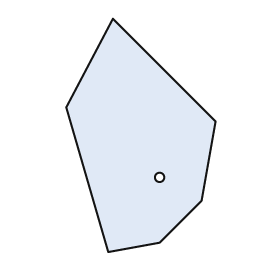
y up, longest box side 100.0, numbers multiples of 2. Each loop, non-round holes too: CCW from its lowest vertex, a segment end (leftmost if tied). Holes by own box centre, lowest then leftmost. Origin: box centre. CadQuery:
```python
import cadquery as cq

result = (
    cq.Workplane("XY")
    .moveTo(-14.0, -50.0)
    .lineTo(8.0, -46.0)
    .lineTo(26.0, -28.0)
    .lineTo(32.0, 6.0)
    .lineTo(-12.0, 50.0)
    .lineTo(-32.0, 12.0)
    .close()
    .moveTo(8.0, -18.0)
    .circle(2.0)
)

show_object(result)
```